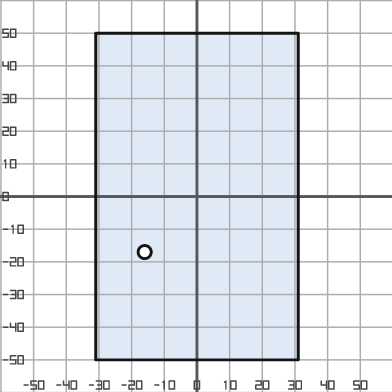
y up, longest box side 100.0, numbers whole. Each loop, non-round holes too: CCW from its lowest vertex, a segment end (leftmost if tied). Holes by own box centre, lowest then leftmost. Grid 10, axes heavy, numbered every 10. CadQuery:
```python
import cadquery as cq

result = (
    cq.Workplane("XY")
    .moveTo(-31.0, -50.0)
    .lineTo(31.0, -50.0)
    .lineTo(31.0, 50.0)
    .lineTo(-31.0, 50.0)
    .close()
    .moveTo(-16.0, -17.0)
    .circle(2.0)
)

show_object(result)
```